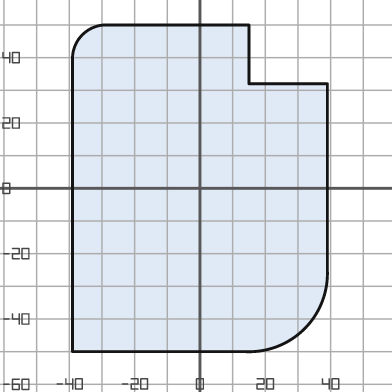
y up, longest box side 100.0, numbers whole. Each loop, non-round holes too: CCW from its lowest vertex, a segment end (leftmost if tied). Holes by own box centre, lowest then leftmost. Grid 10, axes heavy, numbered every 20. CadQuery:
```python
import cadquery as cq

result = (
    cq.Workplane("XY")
    .moveTo(-39.0, -50.0)
    .lineTo(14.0, -50.0)
    .threePointArc((32.0, -43.0), (39.0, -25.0))
    .lineTo(39.0, 32.0)
    .lineTo(15.0, 32.0)
    .lineTo(15.0, 50.0)
    .lineTo(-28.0, 50.0)
    .threePointArc((-36.0, 47.0), (-39.0, 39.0))
    .close()
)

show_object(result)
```